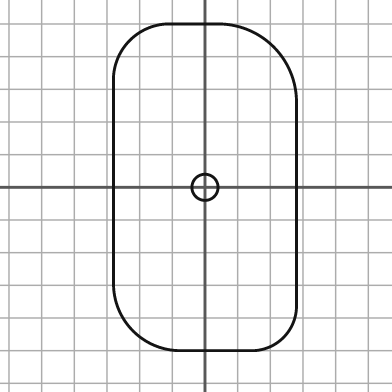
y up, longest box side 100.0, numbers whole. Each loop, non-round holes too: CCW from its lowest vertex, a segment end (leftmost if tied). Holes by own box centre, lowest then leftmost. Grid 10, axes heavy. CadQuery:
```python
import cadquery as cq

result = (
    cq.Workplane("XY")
    .moveTo(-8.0, -50.0)
    .lineTo(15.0, -50.0)
    .threePointArc((24.0, -46.0), (28.0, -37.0))
    .lineTo(28.0, 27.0)
    .threePointArc((21.0, 43.0), (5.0, 50.0))
    .lineTo(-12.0, 50.0)
    .threePointArc((-23.0, 45.0), (-28.0, 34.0))
    .lineTo(-28.0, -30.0)
    .threePointArc((-22.0, -44.0), (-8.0, -50.0))
    .close()
    .moveTo(0.0, 0.0)
    .circle(4.0)
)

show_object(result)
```